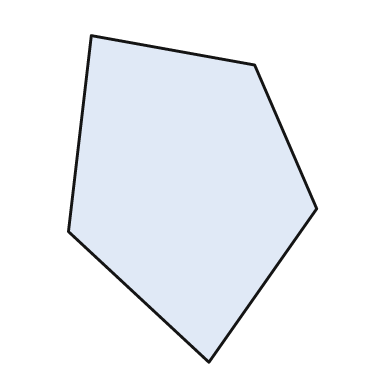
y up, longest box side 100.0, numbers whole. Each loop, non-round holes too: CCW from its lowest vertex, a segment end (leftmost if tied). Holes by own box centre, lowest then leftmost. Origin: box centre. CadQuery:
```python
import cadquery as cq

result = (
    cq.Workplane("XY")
    .moveTo(5.0, -50.0)
    .lineTo(38.0, -3.0)
    .lineTo(19.0, 41.0)
    .lineTo(-31.0, 50.0)
    .lineTo(-38.0, -10.0)
    .close()
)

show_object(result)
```